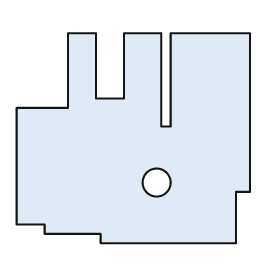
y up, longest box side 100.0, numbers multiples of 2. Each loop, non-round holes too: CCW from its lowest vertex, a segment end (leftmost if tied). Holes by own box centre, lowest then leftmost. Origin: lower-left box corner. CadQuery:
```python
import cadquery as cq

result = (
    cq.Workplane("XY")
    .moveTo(36.0, 0.0)
    .lineTo(94.0, 0.0)
    .lineTo(94.0, 22.0)
    .lineTo(100.0, 22.0)
    .lineTo(100.0, 90.0)
    .lineTo(66.0, 90.0)
    .lineTo(66.0, 50.0)
    .lineTo(62.0, 50.0)
    .lineTo(62.0, 90.0)
    .lineTo(46.0, 90.0)
    .lineTo(46.0, 62.0)
    .lineTo(34.0, 62.0)
    .lineTo(34.0, 90.0)
    .lineTo(22.0, 90.0)
    .lineTo(22.0, 58.0)
    .lineTo(0.0, 58.0)
    .lineTo(0.0, 8.0)
    .lineTo(12.0, 8.0)
    .lineTo(12.0, 4.0)
    .lineTo(36.0, 4.0)
    .close()
    .moveTo(60.0, 26.0)
    .circle(6.0)
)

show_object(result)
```